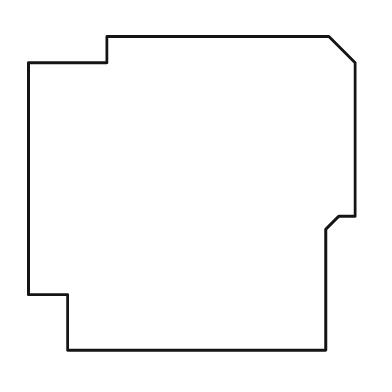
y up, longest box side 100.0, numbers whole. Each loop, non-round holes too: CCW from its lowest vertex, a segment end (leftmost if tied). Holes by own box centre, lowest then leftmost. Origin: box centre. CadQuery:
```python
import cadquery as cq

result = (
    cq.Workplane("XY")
    .moveTo(-38.0, -48.0)
    .lineTo(41.0, -48.0)
    .lineTo(41.0, -11.0)
    .lineTo(45.0, -7.0)
    .lineTo(50.0, -7.0)
    .lineTo(50.0, 40.0)
    .lineTo(42.0, 48.0)
    .lineTo(-26.0, 48.0)
    .lineTo(-26.0, 40.0)
    .lineTo(-50.0, 40.0)
    .lineTo(-50.0, -31.0)
    .lineTo(-38.0, -31.0)
    .close()
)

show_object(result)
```